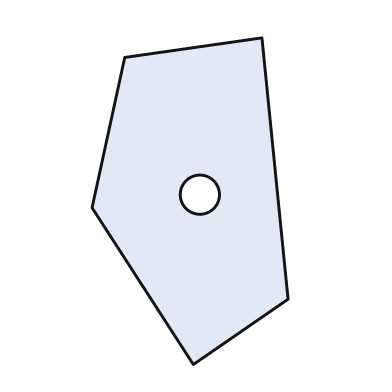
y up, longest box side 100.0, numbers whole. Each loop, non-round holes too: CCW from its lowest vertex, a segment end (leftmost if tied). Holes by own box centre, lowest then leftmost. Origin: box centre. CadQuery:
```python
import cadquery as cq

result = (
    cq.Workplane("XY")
    .moveTo(1.0, -50.0)
    .lineTo(30.0, -30.0)
    .lineTo(22.0, 50.0)
    .lineTo(-20.0, 44.0)
    .lineTo(-30.0, -2.0)
    .close()
    .moveTo(3.0, 2.0)
    .circle(6.0)
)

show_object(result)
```